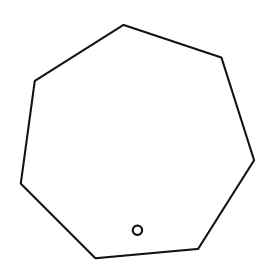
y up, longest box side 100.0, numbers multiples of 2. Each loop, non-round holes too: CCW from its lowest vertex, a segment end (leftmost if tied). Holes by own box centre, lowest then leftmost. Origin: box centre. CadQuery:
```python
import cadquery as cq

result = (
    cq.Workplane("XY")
    .moveTo(-18.0, -50.0)
    .lineTo(26.0, -46.0)
    .lineTo(50.0, -8.0)
    .lineTo(36.0, 36.0)
    .lineTo(-6.0, 50.0)
    .lineTo(-44.0, 26.0)
    .lineTo(-50.0, -18.0)
    .close()
    .moveTo(0.0, -38.0)
    .circle(2.0)
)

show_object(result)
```